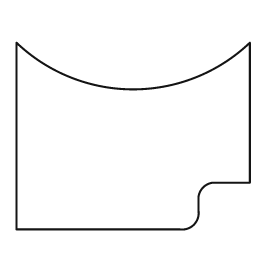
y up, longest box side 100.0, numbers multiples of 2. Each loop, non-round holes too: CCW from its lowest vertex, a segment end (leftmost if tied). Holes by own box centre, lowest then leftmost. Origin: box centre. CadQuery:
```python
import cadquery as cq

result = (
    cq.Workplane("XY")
    .moveTo(-50.0, -40.0)
    .lineTo(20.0, -40.0)
    .threePointArc((26.0, -38.0), (28.0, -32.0))
    .lineTo(28.0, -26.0)
    .threePointArc((30.0, -22.0), (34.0, -20.0))
    .lineTo(50.0, -20.0)
    .lineTo(50.0, 40.0)
    .threePointArc((0.0, 20.0), (-50.0, 40.0))
    .close()
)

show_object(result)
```